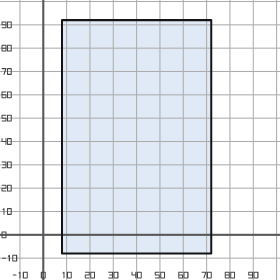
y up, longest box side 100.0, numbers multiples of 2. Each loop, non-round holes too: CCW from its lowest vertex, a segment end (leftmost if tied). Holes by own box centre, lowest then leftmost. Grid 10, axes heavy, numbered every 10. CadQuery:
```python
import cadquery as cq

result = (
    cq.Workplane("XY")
    .moveTo(8.0, -8.0)
    .lineTo(72.0, -8.0)
    .lineTo(72.0, 92.0)
    .lineTo(8.0, 92.0)
    .close()
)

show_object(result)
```